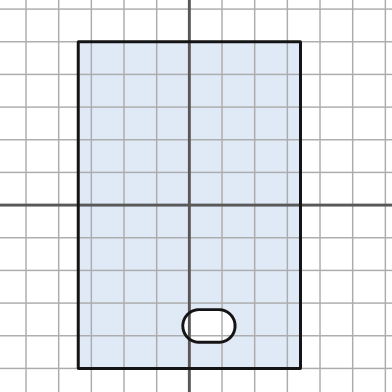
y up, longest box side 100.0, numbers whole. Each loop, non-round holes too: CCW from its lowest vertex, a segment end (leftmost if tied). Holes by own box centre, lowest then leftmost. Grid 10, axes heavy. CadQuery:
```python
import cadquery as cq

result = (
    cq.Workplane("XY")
    .moveTo(-34.0, -50.0)
    .lineTo(34.0, -50.0)
    .lineTo(34.0, 50.0)
    .lineTo(-34.0, 50.0)
    .close()
    .moveTo(3.0, -42.0)
    .lineTo(9.0, -42.0)
    .threePointArc((14.0, -37.0), (9.0, -32.0))
    .lineTo(3.0, -32.0)
    .threePointArc((-2.0, -37.0), (3.0, -42.0))
    .close()
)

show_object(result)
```